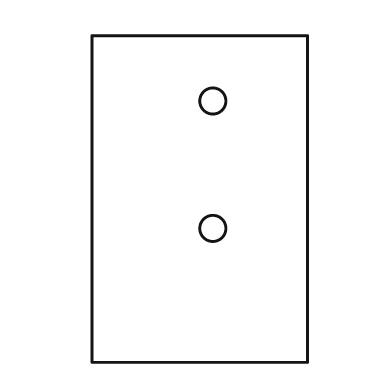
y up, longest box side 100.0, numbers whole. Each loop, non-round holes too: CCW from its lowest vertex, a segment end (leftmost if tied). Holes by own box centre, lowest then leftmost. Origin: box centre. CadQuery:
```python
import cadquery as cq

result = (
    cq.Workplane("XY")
    .moveTo(-33.0, -50.0)
    .lineTo(33.0, -50.0)
    .lineTo(33.0, 50.0)
    .lineTo(-33.0, 50.0)
    .close()
    .moveTo(4.0, -9.0)
    .circle(4.0)
    .moveTo(4.0, 30.0)
    .circle(4.0)
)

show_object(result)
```